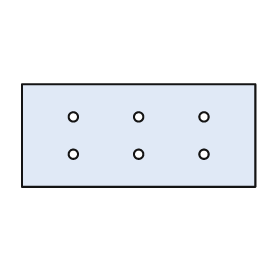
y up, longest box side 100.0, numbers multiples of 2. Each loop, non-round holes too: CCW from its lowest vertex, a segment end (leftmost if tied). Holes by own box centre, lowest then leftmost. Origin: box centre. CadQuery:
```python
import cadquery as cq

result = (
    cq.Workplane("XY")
    .moveTo(-50.0, -22.0)
    .lineTo(50.0, -22.0)
    .lineTo(50.0, 22.0)
    .lineTo(-50.0, 22.0)
    .close()
    .moveTo(-28.0, -8.0)
    .circle(2.0)
    .moveTo(0.0, -8.0)
    .circle(2.0)
    .moveTo(28.0, -8.0)
    .circle(2.0)
    .moveTo(-28.0, 8.0)
    .circle(2.0)
    .moveTo(0.0, 8.0)
    .circle(2.0)
    .moveTo(28.0, 8.0)
    .circle(2.0)
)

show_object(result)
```